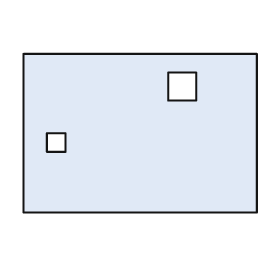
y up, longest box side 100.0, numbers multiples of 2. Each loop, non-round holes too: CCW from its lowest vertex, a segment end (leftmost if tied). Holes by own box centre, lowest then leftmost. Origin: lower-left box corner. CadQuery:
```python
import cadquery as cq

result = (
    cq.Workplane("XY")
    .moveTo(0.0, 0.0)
    .lineTo(100.0, 0.0)
    .lineTo(100.0, 68.0)
    .lineTo(0.0, 68.0)
    .close()
    .moveTo(10.0, 26.0)
    .lineTo(18.0, 26.0)
    .lineTo(18.0, 34.0)
    .lineTo(10.0, 34.0)
    .close()
    .moveTo(62.0, 48.0)
    .lineTo(74.0, 48.0)
    .lineTo(74.0, 60.0)
    .lineTo(62.0, 60.0)
    .close()
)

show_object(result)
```